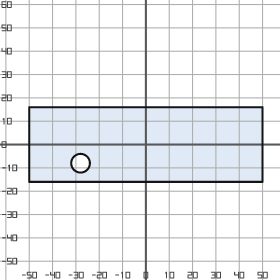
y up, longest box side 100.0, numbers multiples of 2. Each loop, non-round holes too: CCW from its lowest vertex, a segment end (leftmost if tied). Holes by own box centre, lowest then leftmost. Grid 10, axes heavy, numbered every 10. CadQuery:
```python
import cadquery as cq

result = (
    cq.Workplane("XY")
    .moveTo(-50.0, -16.0)
    .lineTo(50.0, -16.0)
    .lineTo(50.0, 16.0)
    .lineTo(-50.0, 16.0)
    .close()
    .moveTo(-28.0, -8.0)
    .circle(4.0)
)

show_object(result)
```